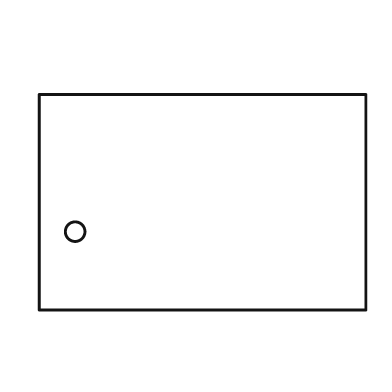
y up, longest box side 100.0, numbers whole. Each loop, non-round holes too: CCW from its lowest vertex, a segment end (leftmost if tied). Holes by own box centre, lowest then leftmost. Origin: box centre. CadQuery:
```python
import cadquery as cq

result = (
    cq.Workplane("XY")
    .moveTo(-50.0, -33.0)
    .lineTo(50.0, -33.0)
    .lineTo(50.0, 33.0)
    .lineTo(-50.0, 33.0)
    .close()
    .moveTo(-39.0, -9.0)
    .circle(3.0)
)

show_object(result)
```